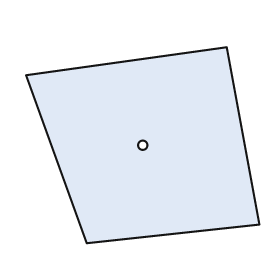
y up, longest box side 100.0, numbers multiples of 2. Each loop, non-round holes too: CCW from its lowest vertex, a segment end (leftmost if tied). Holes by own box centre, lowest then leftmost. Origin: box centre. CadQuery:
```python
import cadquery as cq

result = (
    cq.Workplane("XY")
    .moveTo(-24.0, -42.0)
    .lineTo(50.0, -34.0)
    .lineTo(36.0, 42.0)
    .lineTo(-50.0, 30.0)
    .close()
    .moveTo(0.0, 0.0)
    .circle(2.0)
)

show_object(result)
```